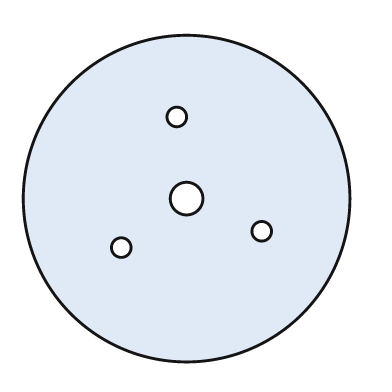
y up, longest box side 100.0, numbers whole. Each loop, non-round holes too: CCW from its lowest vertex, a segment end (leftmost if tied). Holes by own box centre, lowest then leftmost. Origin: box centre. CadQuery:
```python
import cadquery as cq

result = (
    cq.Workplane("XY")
    .moveTo(0.0, 0.0)
    .circle(50.0)
    .moveTo(-20.0, -15.0)
    .circle(3.0)
    .moveTo(23.0, -10.0)
    .circle(3.0)
    .moveTo(0.0, 0.0)
    .circle(5.0)
    .moveTo(-3.0, 25.0)
    .circle(3.0)
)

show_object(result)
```